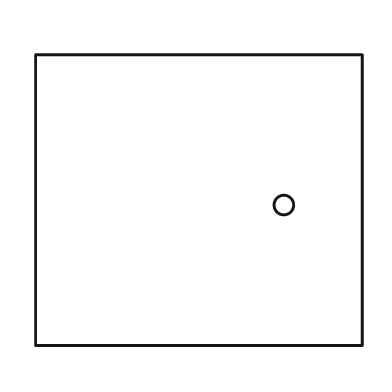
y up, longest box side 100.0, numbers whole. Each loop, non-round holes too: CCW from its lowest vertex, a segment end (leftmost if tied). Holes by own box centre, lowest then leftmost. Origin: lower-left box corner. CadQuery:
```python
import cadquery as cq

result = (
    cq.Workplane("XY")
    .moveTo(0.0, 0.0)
    .lineTo(100.0, 0.0)
    .lineTo(100.0, 89.0)
    .lineTo(0.0, 89.0)
    .close()
    .moveTo(76.0, 43.0)
    .circle(3.0)
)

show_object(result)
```